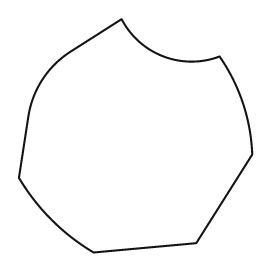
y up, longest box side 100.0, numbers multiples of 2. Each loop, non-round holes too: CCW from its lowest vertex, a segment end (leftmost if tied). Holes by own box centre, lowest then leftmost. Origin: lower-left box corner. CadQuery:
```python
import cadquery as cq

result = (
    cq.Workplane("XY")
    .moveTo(32.0, 0.0)
    .lineTo(76.0, 4.0)
    .lineTo(100.0, 42.0)
    .threePointArc((96.0, 64.0), (86.0, 84.0))
    .threePointArc((62.0, 84.0), (44.0, 100.0))
    .lineTo(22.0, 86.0)
    .threePointArc((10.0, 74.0), (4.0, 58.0))
    .lineTo(0.0, 32.0)
    .threePointArc((14.0, 14.0), (32.0, 0.0))
    .close()
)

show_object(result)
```